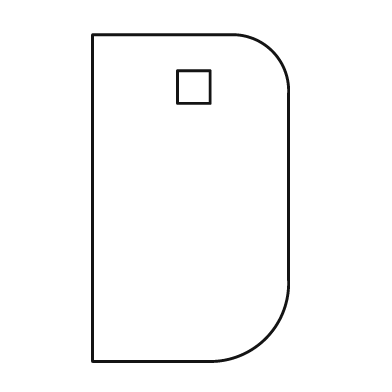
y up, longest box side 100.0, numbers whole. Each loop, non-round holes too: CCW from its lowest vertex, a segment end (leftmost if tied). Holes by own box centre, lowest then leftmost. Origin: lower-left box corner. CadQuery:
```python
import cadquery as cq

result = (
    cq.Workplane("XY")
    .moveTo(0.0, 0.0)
    .lineTo(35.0, 0.0)
    .threePointArc((53.0, 7.0), (60.0, 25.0))
    .lineTo(60.0, 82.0)
    .threePointArc((55.0, 95.0), (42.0, 100.0))
    .lineTo(0.0, 100.0)
    .close()
    .moveTo(26.0, 79.0)
    .lineTo(36.0, 79.0)
    .lineTo(36.0, 89.0)
    .lineTo(26.0, 89.0)
    .close()
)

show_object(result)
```